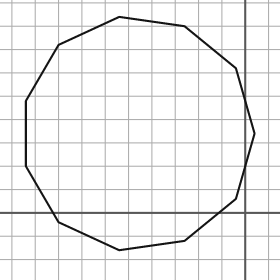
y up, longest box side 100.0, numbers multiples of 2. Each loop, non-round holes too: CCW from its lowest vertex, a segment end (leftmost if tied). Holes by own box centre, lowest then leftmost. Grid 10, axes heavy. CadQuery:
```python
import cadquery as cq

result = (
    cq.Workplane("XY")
    .moveTo(-54.0, -16.0)
    .lineTo(-26.0, -12.0)
    .lineTo(-4.0, 6.0)
    .lineTo(4.0, 34.0)
    .lineTo(-4.0, 62.0)
    .lineTo(-26.0, 80.0)
    .lineTo(-54.0, 84.0)
    .lineTo(-80.0, 72.0)
    .lineTo(-94.0, 48.0)
    .lineTo(-94.0, 20.0)
    .lineTo(-80.0, -4.0)
    .close()
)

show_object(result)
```